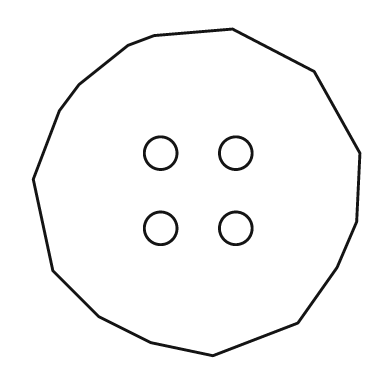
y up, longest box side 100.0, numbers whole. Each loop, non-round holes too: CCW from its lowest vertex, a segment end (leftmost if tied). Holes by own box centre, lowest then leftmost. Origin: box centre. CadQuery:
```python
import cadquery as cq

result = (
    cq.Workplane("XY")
    .moveTo(5.0, -50.0)
    .lineTo(31.0, -40.0)
    .lineTo(43.0, -23.0)
    .lineTo(49.0, -9.0)
    .lineTo(50.0, 12.0)
    .lineTo(36.0, 37.0)
    .lineTo(11.0, 50.0)
    .lineTo(-13.0, 48.0)
    .lineTo(-21.0, 45.0)
    .lineTo(-36.0, 33.0)
    .lineTo(-42.0, 25.0)
    .lineTo(-50.0, 4.0)
    .lineTo(-44.0, -24.0)
    .lineTo(-30.0, -38.0)
    .lineTo(-14.0, -46.0)
    .close()
    .moveTo(-11.0, -11.0)
    .circle(5.0)
    .moveTo(12.0, -11.0)
    .circle(5.0)
    .moveTo(-11.0, 12.0)
    .circle(5.0)
    .moveTo(12.0, 12.0)
    .circle(5.0)
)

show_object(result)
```